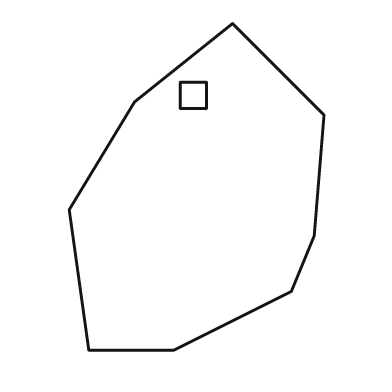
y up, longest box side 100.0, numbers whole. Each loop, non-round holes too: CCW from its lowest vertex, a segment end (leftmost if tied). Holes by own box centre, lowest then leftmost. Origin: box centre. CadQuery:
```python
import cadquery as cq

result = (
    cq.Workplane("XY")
    .moveTo(-33.0, -50.0)
    .lineTo(-7.0, -50.0)
    .lineTo(29.0, -32.0)
    .lineTo(36.0, -15.0)
    .lineTo(39.0, 22.0)
    .lineTo(11.0, 50.0)
    .lineTo(-19.0, 26.0)
    .lineTo(-39.0, -7.0)
    .close()
    .moveTo(-5.0, 24.0)
    .lineTo(3.0, 24.0)
    .lineTo(3.0, 32.0)
    .lineTo(-5.0, 32.0)
    .close()
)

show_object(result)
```